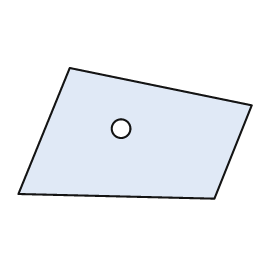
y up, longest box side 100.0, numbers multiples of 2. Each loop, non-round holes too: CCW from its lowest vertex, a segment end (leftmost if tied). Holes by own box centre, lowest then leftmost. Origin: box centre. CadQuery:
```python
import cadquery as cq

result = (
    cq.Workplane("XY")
    .moveTo(34.0, -28.0)
    .lineTo(50.0, 12.0)
    .lineTo(-28.0, 28.0)
    .lineTo(-50.0, -26.0)
    .close()
    .moveTo(-6.0, 2.0)
    .circle(4.0)
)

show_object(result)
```